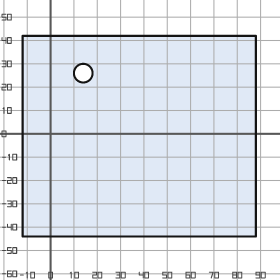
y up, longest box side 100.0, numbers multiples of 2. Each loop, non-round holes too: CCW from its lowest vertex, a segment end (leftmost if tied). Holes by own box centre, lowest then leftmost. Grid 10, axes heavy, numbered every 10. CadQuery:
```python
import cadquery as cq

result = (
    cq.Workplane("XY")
    .moveTo(-12.0, -44.0)
    .lineTo(88.0, -44.0)
    .lineTo(88.0, 42.0)
    .lineTo(-12.0, 42.0)
    .close()
    .moveTo(14.0, 26.0)
    .circle(4.0)
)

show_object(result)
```